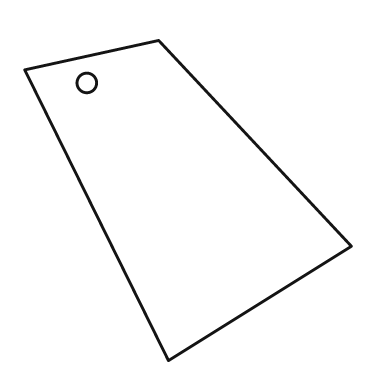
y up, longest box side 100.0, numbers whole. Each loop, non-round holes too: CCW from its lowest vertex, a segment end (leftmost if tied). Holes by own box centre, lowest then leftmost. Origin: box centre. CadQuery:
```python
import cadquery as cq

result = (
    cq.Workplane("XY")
    .moveTo(-6.0, -49.0)
    .lineTo(50.0, -14.0)
    .lineTo(-9.0, 49.0)
    .lineTo(-50.0, 40.0)
    .close()
    .moveTo(-31.0, 36.0)
    .circle(3.0)
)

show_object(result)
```